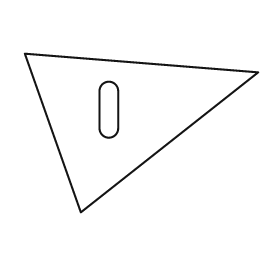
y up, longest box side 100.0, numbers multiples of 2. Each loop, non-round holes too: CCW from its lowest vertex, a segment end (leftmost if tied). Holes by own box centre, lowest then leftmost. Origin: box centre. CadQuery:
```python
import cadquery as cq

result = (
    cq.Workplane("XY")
    .moveTo(-26.0, -34.0)
    .lineTo(50.0, 26.0)
    .lineTo(-50.0, 34.0)
    .close()
    .moveTo(-18.0, 2.0)
    .threePointArc((-14.0, -2.0), (-10.0, 2.0))
    .lineTo(-10.0, 18.0)
    .threePointArc((-14.0, 22.0), (-18.0, 18.0))
    .close()
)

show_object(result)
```